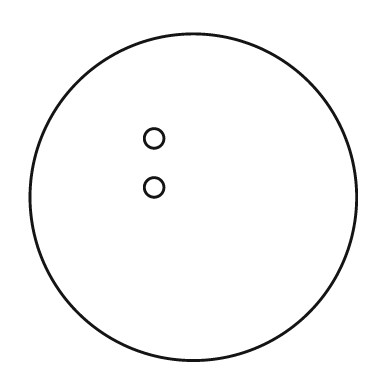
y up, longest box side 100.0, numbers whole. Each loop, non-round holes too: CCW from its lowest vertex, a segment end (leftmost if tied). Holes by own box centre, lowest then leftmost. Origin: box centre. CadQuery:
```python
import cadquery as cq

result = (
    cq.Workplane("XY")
    .moveTo(0.0, 0.0)
    .circle(50.0)
    .moveTo(-12.0, 3.0)
    .circle(3.0)
    .moveTo(-12.0, 18.0)
    .circle(3.0)
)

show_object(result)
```